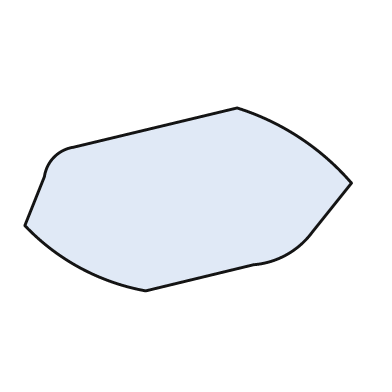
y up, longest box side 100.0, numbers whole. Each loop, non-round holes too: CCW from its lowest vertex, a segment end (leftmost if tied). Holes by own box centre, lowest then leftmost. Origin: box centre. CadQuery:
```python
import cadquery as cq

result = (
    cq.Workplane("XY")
    .moveTo(-13.0, -28.0)
    .lineTo(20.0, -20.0)
    .threePointArc((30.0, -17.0), (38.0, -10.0))
    .lineTo(50.0, 5.0)
    .threePointArc((34.0, 19.0), (15.0, 28.0))
    .lineTo(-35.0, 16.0)
    .threePointArc((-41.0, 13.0), (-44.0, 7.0))
    .lineTo(-50.0, -8.0)
    .threePointArc((-33.0, -21.0), (-13.0, -28.0))
    .close()
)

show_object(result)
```